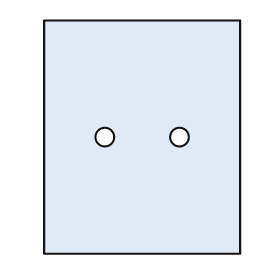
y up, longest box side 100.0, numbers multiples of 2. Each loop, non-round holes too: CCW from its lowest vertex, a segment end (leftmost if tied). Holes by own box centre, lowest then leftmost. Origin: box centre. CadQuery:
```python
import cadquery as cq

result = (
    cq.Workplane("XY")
    .moveTo(-42.0, -50.0)
    .lineTo(42.0, -50.0)
    .lineTo(42.0, 50.0)
    .lineTo(-42.0, 50.0)
    .close()
    .moveTo(-16.0, 0.0)
    .circle(4.0)
    .moveTo(16.0, 0.0)
    .circle(4.0)
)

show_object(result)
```